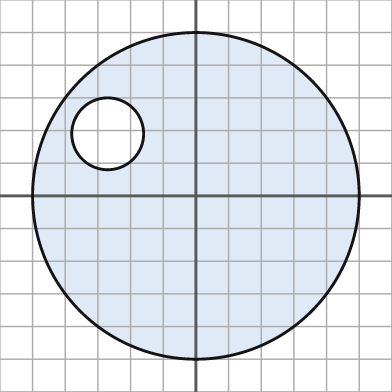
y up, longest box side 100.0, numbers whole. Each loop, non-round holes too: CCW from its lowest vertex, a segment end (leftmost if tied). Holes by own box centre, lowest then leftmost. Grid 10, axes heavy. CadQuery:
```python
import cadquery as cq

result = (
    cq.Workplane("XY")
    .moveTo(0.0, 0.0)
    .circle(50.0)
    .moveTo(-27.0, 19.0)
    .circle(11.0)
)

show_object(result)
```